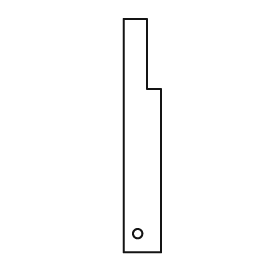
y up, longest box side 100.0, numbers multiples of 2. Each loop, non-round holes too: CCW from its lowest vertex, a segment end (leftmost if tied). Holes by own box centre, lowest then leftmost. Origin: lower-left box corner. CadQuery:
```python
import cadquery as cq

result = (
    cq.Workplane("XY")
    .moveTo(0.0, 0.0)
    .lineTo(16.0, 0.0)
    .lineTo(16.0, 70.0)
    .lineTo(10.0, 70.0)
    .lineTo(10.0, 100.0)
    .lineTo(0.0, 100.0)
    .close()
    .moveTo(6.0, 8.0)
    .circle(2.0)
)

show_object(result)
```